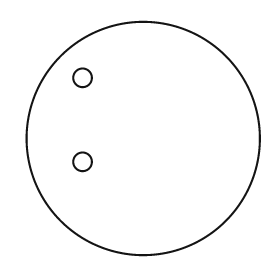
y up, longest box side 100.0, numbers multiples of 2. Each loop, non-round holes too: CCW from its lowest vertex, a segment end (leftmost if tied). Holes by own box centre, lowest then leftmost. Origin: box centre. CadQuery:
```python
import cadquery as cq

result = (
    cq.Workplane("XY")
    .moveTo(0.0, 0.0)
    .circle(50.0)
    .moveTo(-26.0, -10.0)
    .circle(4.0)
    .moveTo(-26.0, 26.0)
    .circle(4.0)
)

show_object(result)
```